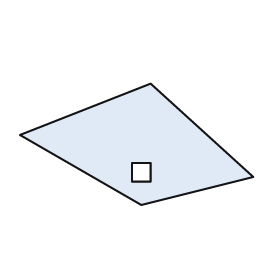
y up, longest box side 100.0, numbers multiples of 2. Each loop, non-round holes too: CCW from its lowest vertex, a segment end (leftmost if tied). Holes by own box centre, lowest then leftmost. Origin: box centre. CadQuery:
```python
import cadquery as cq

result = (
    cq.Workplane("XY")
    .moveTo(2.0, -26.0)
    .lineTo(50.0, -14.0)
    .lineTo(6.0, 26.0)
    .lineTo(-50.0, 4.0)
    .close()
    .moveTo(-2.0, -16.0)
    .lineTo(6.0, -16.0)
    .lineTo(6.0, -8.0)
    .lineTo(-2.0, -8.0)
    .close()
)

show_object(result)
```